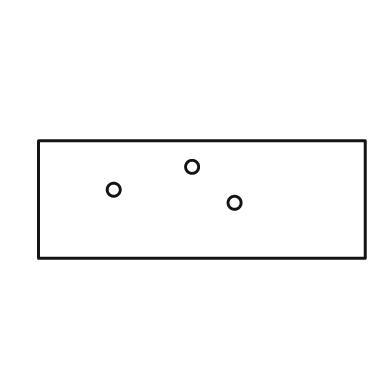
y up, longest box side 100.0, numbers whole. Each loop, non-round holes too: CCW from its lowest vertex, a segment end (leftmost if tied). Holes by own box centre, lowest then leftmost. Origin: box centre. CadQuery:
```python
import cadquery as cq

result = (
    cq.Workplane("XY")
    .moveTo(-50.0, -18.0)
    .lineTo(50.0, -18.0)
    .lineTo(50.0, 18.0)
    .lineTo(-50.0, 18.0)
    .close()
    .moveTo(10.0, -1.0)
    .circle(2.0)
    .moveTo(-27.0, 3.0)
    .circle(2.0)
    .moveTo(-3.0, 10.0)
    .circle(2.0)
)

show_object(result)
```